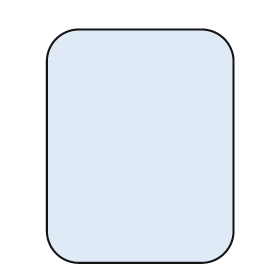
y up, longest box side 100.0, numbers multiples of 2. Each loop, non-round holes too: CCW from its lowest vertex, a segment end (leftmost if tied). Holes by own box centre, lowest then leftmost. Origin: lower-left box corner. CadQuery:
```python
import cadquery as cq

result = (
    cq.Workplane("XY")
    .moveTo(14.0, 0.0)
    .lineTo(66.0, 0.0)
    .threePointArc((76.0, 4.0), (80.0, 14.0))
    .lineTo(80.0, 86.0)
    .threePointArc((76.0, 96.0), (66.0, 100.0))
    .lineTo(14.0, 100.0)
    .threePointArc((4.0, 96.0), (0.0, 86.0))
    .lineTo(0.0, 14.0)
    .threePointArc((4.0, 4.0), (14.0, 0.0))
    .close()
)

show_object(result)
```